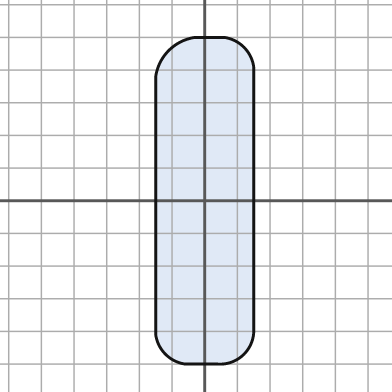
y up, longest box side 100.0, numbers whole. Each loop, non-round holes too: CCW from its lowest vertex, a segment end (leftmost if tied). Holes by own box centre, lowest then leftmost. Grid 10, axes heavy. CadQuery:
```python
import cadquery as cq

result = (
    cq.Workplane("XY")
    .moveTo(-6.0, -50.0)
    .lineTo(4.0, -50.0)
    .threePointArc((12.0, -47.0), (15.0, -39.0))
    .lineTo(15.0, 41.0)
    .threePointArc((12.0, 47.0), (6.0, 50.0))
    .lineTo(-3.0, 50.0)
    .threePointArc((-11.0, 46.0), (-15.0, 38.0))
    .lineTo(-15.0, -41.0)
    .threePointArc((-12.0, -47.0), (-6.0, -50.0))
    .close()
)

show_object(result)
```